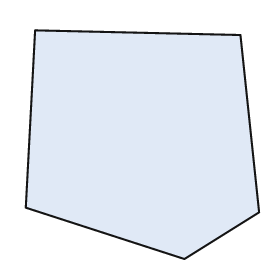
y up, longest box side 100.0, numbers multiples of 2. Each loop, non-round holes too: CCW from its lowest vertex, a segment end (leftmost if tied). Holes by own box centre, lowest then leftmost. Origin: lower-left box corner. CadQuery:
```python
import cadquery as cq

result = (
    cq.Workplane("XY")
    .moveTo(68.0, 0.0)
    .lineTo(100.0, 20.0)
    .lineTo(92.0, 96.0)
    .lineTo(4.0, 98.0)
    .lineTo(0.0, 22.0)
    .close()
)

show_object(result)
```